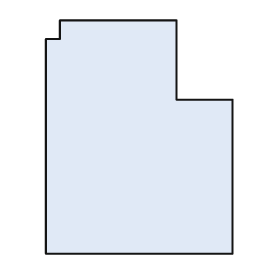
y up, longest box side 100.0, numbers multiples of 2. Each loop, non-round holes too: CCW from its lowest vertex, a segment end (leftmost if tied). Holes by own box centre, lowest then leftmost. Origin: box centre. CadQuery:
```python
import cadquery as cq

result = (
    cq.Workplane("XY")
    .moveTo(-40.0, -50.0)
    .lineTo(40.0, -50.0)
    .lineTo(40.0, 16.0)
    .lineTo(16.0, 16.0)
    .lineTo(16.0, 50.0)
    .lineTo(-34.0, 50.0)
    .lineTo(-34.0, 42.0)
    .lineTo(-40.0, 42.0)
    .close()
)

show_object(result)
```